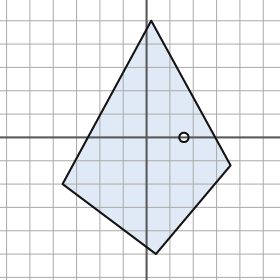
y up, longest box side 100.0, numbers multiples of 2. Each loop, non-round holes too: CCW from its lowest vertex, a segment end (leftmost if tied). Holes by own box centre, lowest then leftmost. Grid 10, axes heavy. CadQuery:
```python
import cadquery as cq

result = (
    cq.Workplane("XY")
    .moveTo(4.0, -50.0)
    .lineTo(36.0, -12.0)
    .lineTo(2.0, 50.0)
    .lineTo(-36.0, -20.0)
    .close()
    .moveTo(16.0, 0.0)
    .circle(2.0)
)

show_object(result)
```